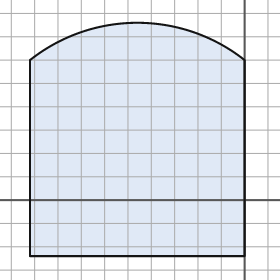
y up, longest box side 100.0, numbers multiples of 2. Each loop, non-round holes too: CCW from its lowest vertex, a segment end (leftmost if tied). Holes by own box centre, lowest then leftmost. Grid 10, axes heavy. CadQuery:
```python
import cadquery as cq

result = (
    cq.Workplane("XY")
    .moveTo(-92.0, -24.0)
    .lineTo(0.0, -24.0)
    .lineTo(0.0, 60.0)
    .threePointArc((-46.0, 76.0), (-92.0, 60.0))
    .close()
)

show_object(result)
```